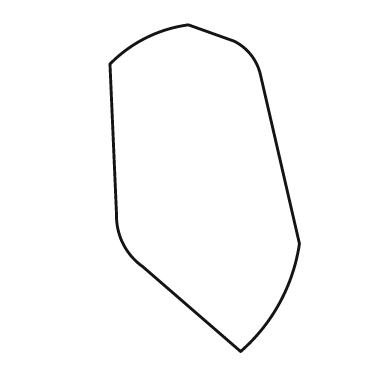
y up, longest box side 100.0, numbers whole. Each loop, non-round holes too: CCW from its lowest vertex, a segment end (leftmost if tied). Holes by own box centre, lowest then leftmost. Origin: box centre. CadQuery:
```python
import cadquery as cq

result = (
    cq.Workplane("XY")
    .moveTo(11.0, -50.0)
    .threePointArc((23.0, -35.0), (29.0, -17.0))
    .lineTo(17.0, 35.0)
    .threePointArc((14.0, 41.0), (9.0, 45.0))
    .lineTo(-5.0, 50.0)
    .threePointArc((-18.0, 46.0), (-29.0, 38.0))
    .lineTo(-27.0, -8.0)
    .threePointArc((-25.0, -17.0), (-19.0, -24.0))
    .close()
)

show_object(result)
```